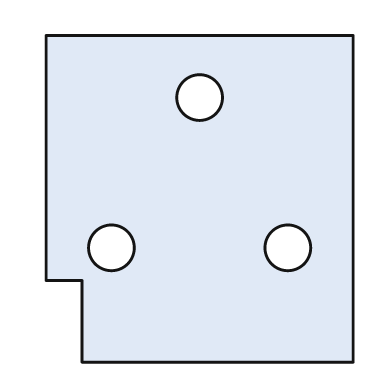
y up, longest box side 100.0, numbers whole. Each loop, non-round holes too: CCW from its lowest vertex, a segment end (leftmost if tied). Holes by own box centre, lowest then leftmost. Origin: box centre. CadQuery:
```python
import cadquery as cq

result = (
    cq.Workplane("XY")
    .moveTo(-36.0, -50.0)
    .lineTo(47.0, -50.0)
    .lineTo(47.0, 50.0)
    .lineTo(-47.0, 50.0)
    .lineTo(-47.0, -25.0)
    .lineTo(-36.0, -25.0)
    .close()
    .moveTo(-27.0, -15.0)
    .circle(7.0)
    .moveTo(27.0, -15.0)
    .circle(7.0)
    .moveTo(0.0, 31.0)
    .circle(7.0)
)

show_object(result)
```